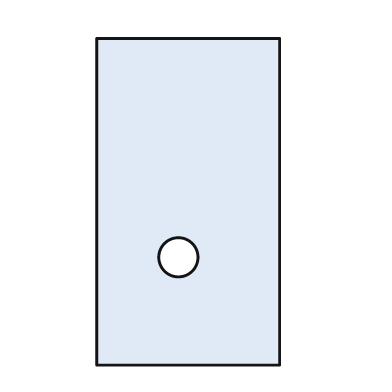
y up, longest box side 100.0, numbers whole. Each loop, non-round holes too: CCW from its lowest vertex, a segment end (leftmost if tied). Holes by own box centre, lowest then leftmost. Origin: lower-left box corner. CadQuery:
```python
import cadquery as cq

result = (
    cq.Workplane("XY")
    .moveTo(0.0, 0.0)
    .lineTo(56.0, 0.0)
    .lineTo(56.0, 100.0)
    .lineTo(0.0, 100.0)
    .close()
    .moveTo(25.0, 33.0)
    .circle(6.0)
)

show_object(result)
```